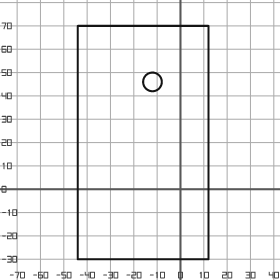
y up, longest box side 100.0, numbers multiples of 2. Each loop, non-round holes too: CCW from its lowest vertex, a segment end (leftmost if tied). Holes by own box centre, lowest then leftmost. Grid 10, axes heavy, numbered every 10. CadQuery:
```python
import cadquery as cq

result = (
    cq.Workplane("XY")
    .moveTo(-44.0, -30.0)
    .lineTo(12.0, -30.0)
    .lineTo(12.0, 70.0)
    .lineTo(-44.0, 70.0)
    .close()
    .moveTo(-12.0, 46.0)
    .circle(4.0)
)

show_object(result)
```